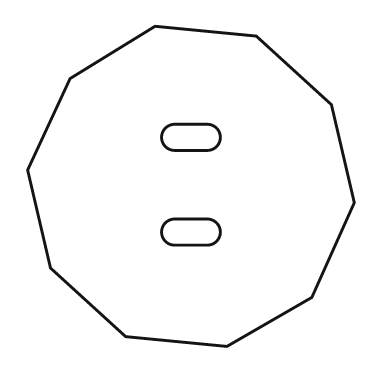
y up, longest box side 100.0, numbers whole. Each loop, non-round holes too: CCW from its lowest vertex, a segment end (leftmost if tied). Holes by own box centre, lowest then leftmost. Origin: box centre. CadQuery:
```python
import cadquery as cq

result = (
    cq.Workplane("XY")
    .moveTo(11.0, -49.0)
    .lineTo(37.0, -34.0)
    .lineTo(50.0, -5.0)
    .lineTo(43.0, 25.0)
    .lineTo(20.0, 46.0)
    .lineTo(-11.0, 49.0)
    .lineTo(-37.0, 33.0)
    .lineTo(-50.0, 5.0)
    .lineTo(-43.0, -25.0)
    .lineTo(-20.0, -46.0)
    .close()
    .moveTo(-5.0, -18.0)
    .lineTo(5.0, -18.0)
    .threePointArc((9.0, -14.0), (5.0, -10.0))
    .lineTo(-5.0, -10.0)
    .threePointArc((-9.0, -14.0), (-5.0, -18.0))
    .close()
    .moveTo(-5.0, 11.0)
    .lineTo(5.0, 11.0)
    .threePointArc((9.0, 15.0), (5.0, 19.0))
    .lineTo(-5.0, 19.0)
    .threePointArc((-9.0, 15.0), (-5.0, 11.0))
    .close()
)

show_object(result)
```